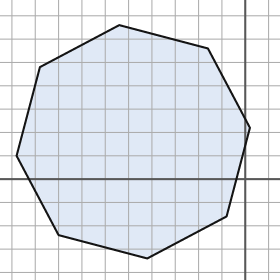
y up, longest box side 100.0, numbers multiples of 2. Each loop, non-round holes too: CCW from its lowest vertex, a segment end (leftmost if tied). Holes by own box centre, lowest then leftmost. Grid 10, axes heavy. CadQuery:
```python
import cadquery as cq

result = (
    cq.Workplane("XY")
    .moveTo(-42.0, -34.0)
    .lineTo(-8.0, -16.0)
    .lineTo(2.0, 22.0)
    .lineTo(-16.0, 56.0)
    .lineTo(-54.0, 66.0)
    .lineTo(-88.0, 48.0)
    .lineTo(-98.0, 10.0)
    .lineTo(-80.0, -24.0)
    .close()
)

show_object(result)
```